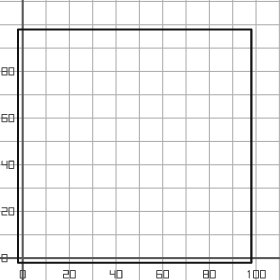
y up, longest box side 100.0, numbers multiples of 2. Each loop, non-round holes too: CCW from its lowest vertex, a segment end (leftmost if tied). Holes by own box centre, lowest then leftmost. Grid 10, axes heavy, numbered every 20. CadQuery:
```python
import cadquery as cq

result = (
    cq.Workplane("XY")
    .moveTo(-2.0, -2.0)
    .lineTo(98.0, -2.0)
    .lineTo(98.0, 98.0)
    .lineTo(-2.0, 98.0)
    .close()
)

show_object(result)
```